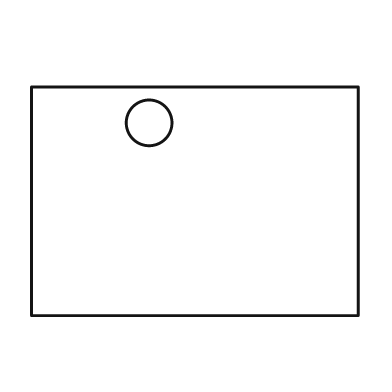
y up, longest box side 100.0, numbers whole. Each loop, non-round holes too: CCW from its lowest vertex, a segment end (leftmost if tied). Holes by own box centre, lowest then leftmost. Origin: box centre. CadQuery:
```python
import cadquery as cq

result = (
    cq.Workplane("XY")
    .moveTo(-50.0, -35.0)
    .lineTo(50.0, -35.0)
    .lineTo(50.0, 35.0)
    .lineTo(-50.0, 35.0)
    .close()
    .moveTo(-14.0, 24.0)
    .circle(7.0)
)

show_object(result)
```